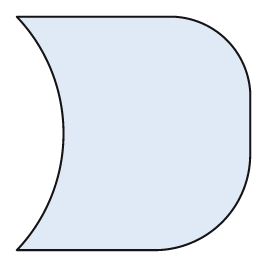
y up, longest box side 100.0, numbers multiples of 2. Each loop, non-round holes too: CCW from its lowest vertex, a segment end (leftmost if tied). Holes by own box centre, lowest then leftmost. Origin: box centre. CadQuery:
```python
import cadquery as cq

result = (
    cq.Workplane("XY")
    .moveTo(-50.0, -50.0)
    .lineTo(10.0, -50.0)
    .threePointArc((38.0, -38.0), (50.0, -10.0))
    .lineTo(50.0, 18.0)
    .threePointArc((40.0, 40.0), (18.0, 50.0))
    .lineTo(-50.0, 50.0)
    .threePointArc((-30.0, 0.0), (-50.0, -50.0))
    .close()
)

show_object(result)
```